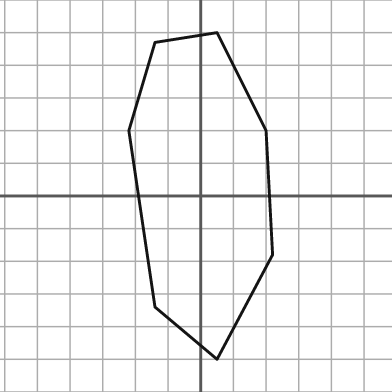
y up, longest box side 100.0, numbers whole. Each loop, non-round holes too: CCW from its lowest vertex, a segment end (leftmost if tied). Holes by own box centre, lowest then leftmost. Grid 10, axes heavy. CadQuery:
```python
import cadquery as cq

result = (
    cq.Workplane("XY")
    .moveTo(5.0, -50.0)
    .lineTo(22.0, -18.0)
    .lineTo(20.0, 20.0)
    .lineTo(5.0, 50.0)
    .lineTo(-14.0, 47.0)
    .lineTo(-22.0, 20.0)
    .lineTo(-14.0, -34.0)
    .close()
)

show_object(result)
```